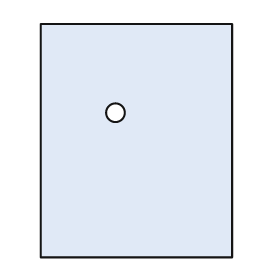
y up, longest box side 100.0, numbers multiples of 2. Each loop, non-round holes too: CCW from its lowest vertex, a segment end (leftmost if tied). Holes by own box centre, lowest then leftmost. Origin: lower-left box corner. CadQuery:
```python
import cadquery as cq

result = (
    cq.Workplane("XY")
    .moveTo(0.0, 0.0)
    .lineTo(82.0, 0.0)
    .lineTo(82.0, 100.0)
    .lineTo(0.0, 100.0)
    .close()
    .moveTo(32.0, 62.0)
    .circle(4.0)
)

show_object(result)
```